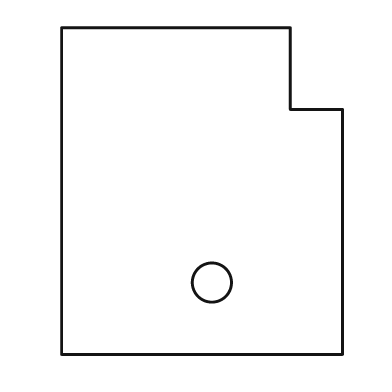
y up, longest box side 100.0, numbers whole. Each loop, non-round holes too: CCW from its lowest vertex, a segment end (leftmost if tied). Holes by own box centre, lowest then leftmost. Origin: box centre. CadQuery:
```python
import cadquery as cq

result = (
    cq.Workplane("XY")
    .moveTo(-43.0, -50.0)
    .lineTo(43.0, -50.0)
    .lineTo(43.0, 25.0)
    .lineTo(27.0, 25.0)
    .lineTo(27.0, 50.0)
    .lineTo(-43.0, 50.0)
    .close()
    .moveTo(3.0, -28.0)
    .circle(6.0)
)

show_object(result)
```